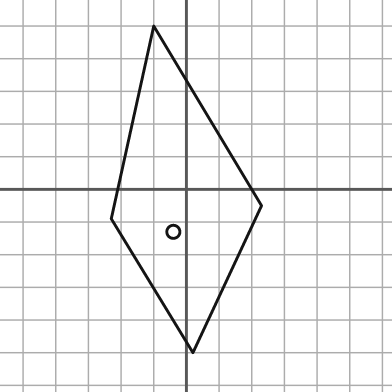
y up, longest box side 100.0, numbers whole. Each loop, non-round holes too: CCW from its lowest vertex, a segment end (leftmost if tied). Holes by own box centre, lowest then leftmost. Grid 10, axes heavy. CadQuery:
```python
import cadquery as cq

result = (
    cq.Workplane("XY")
    .moveTo(2.0, -50.0)
    .lineTo(23.0, -5.0)
    .lineTo(-10.0, 50.0)
    .lineTo(-23.0, -9.0)
    .close()
    .moveTo(-4.0, -13.0)
    .circle(2.0)
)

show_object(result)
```